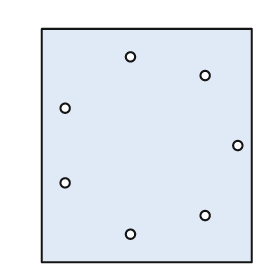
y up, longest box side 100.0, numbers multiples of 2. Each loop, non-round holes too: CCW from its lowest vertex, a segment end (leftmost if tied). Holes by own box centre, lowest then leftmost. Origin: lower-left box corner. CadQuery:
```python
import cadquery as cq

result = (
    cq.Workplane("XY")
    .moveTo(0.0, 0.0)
    .lineTo(90.0, 0.0)
    .lineTo(90.0, 100.0)
    .lineTo(0.0, 100.0)
    .close()
    .moveTo(38.0, 12.0)
    .circle(2.0)
    .moveTo(70.0, 20.0)
    .circle(2.0)
    .moveTo(10.0, 34.0)
    .circle(2.0)
    .moveTo(84.0, 50.0)
    .circle(2.0)
    .moveTo(10.0, 66.0)
    .circle(2.0)
    .moveTo(70.0, 80.0)
    .circle(2.0)
    .moveTo(38.0, 88.0)
    .circle(2.0)
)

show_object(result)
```